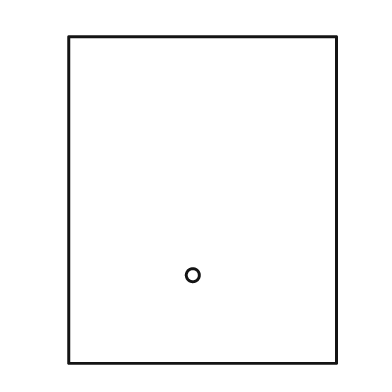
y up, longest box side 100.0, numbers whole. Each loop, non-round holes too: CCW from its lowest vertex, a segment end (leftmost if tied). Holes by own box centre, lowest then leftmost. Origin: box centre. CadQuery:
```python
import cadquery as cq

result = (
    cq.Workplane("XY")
    .moveTo(-41.0, -50.0)
    .lineTo(41.0, -50.0)
    .lineTo(41.0, 50.0)
    .lineTo(-41.0, 50.0)
    .close()
    .moveTo(-3.0, -23.0)
    .circle(2.0)
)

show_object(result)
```